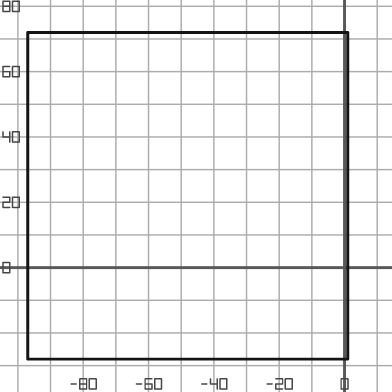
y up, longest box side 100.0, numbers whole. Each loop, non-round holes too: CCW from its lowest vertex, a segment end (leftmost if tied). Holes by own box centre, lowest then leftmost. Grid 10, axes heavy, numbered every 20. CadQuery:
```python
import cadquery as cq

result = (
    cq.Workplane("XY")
    .moveTo(-97.0, -28.0)
    .lineTo(1.0, -28.0)
    .lineTo(1.0, 72.0)
    .lineTo(-97.0, 72.0)
    .close()
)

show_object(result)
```